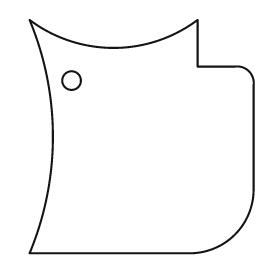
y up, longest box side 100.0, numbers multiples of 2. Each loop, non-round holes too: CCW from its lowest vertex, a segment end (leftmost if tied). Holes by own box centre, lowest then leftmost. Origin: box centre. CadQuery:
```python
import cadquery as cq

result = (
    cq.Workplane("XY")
    .moveTo(-48.0, -50.0)
    .lineTo(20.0, -50.0)
    .threePointArc((40.0, -42.0), (48.0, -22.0))
    .lineTo(48.0, 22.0)
    .threePointArc((46.0, 28.0), (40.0, 30.0))
    .lineTo(24.0, 30.0)
    .lineTo(24.0, 50.0)
    .threePointArc((-12.0, 38.0), (-48.0, 50.0))
    .threePointArc((-38.0, 0.0), (-48.0, -50.0))
    .close()
    .moveTo(-30.0, 24.0)
    .circle(4.0)
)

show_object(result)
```